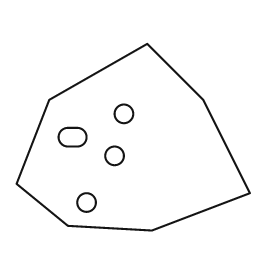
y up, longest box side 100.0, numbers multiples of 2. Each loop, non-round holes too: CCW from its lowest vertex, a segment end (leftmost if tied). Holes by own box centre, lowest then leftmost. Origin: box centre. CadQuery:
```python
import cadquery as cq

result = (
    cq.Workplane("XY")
    .moveTo(8.0, -40.0)
    .lineTo(50.0, -24.0)
    .lineTo(30.0, 16.0)
    .lineTo(6.0, 40.0)
    .lineTo(-36.0, 16.0)
    .lineTo(-50.0, -20.0)
    .lineTo(-28.0, -38.0)
    .close()
    .moveTo(-20.0, -28.0)
    .circle(4.0)
    .moveTo(-8.0, -8.0)
    .circle(4.0)
    .moveTo(-28.0, -4.0)
    .lineTo(-24.0, -4.0)
    .threePointArc((-20.0, 0.0), (-24.0, 4.0))
    .lineTo(-28.0, 4.0)
    .threePointArc((-32.0, 0.0), (-28.0, -4.0))
    .close()
    .moveTo(-4.0, 10.0)
    .circle(4.0)
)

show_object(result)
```